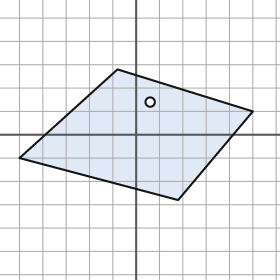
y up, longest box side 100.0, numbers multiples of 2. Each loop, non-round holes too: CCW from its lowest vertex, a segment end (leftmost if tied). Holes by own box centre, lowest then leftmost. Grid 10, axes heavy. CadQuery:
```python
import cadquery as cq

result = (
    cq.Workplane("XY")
    .moveTo(18.0, -28.0)
    .lineTo(50.0, 10.0)
    .lineTo(-8.0, 28.0)
    .lineTo(-50.0, -10.0)
    .close()
    .moveTo(6.0, 14.0)
    .circle(2.0)
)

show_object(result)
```